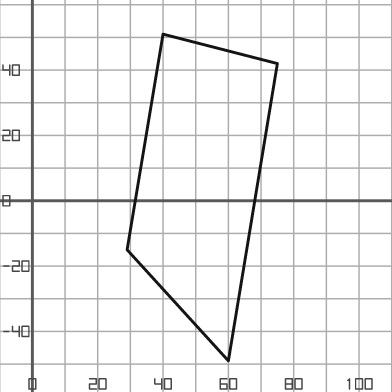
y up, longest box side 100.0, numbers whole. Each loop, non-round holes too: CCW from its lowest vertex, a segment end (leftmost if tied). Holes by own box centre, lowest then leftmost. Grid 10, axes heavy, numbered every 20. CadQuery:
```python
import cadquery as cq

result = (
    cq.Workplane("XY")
    .moveTo(60.0, -49.0)
    .lineTo(75.0, 42.0)
    .lineTo(40.0, 51.0)
    .lineTo(29.0, -15.0)
    .close()
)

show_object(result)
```